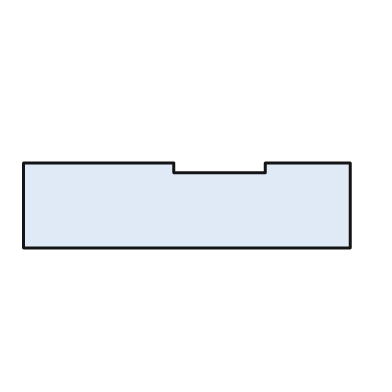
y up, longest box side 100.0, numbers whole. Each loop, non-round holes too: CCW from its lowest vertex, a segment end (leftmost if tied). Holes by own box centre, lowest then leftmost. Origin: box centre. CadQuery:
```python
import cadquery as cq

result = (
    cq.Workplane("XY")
    .moveTo(-50.0, -13.0)
    .lineTo(50.0, -13.0)
    .lineTo(50.0, 13.0)
    .lineTo(24.0, 13.0)
    .lineTo(24.0, 10.0)
    .lineTo(-4.0, 10.0)
    .lineTo(-4.0, 13.0)
    .lineTo(-50.0, 13.0)
    .close()
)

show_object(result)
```